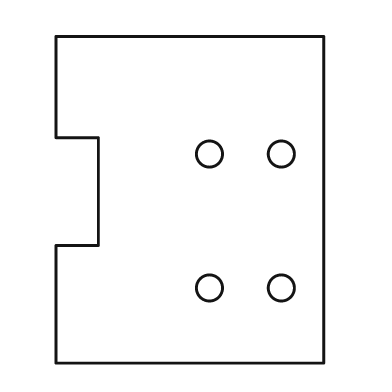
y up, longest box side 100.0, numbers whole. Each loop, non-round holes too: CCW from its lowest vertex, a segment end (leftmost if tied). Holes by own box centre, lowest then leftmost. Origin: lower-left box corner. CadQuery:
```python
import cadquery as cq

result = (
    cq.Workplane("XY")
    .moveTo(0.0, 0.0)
    .lineTo(82.0, 0.0)
    .lineTo(82.0, 100.0)
    .lineTo(0.0, 100.0)
    .lineTo(0.0, 69.0)
    .lineTo(13.0, 69.0)
    .lineTo(13.0, 36.0)
    .lineTo(0.0, 36.0)
    .close()
    .moveTo(47.0, 23.0)
    .circle(4.0)
    .moveTo(69.0, 23.0)
    .circle(4.0)
    .moveTo(47.0, 64.0)
    .circle(4.0)
    .moveTo(69.0, 64.0)
    .circle(4.0)
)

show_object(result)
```